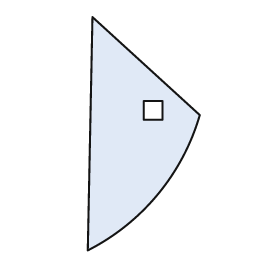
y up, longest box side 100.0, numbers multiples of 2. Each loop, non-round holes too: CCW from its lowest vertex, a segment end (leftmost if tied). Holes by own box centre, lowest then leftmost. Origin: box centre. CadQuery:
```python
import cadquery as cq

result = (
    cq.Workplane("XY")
    .moveTo(-24.0, -50.0)
    .threePointArc((6.0, -26.0), (24.0, 8.0))
    .lineTo(-22.0, 50.0)
    .close()
    .moveTo(0.0, 6.0)
    .lineTo(8.0, 6.0)
    .lineTo(8.0, 14.0)
    .lineTo(0.0, 14.0)
    .close()
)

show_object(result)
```